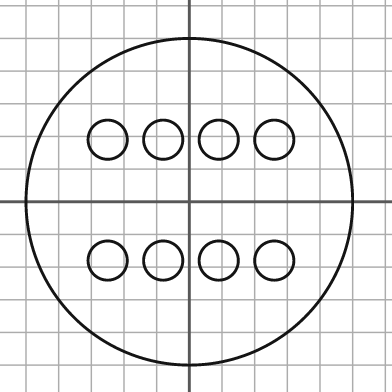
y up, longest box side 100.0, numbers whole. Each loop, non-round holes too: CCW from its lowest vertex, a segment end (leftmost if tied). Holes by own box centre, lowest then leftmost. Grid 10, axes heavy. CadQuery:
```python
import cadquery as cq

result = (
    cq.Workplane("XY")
    .moveTo(0.0, 0.0)
    .circle(50.0)
    .moveTo(-25.0, -18.0)
    .circle(6.0)
    .moveTo(-8.0, -18.0)
    .circle(6.0)
    .moveTo(9.0, -18.0)
    .circle(6.0)
    .moveTo(26.0, -18.0)
    .circle(6.0)
    .moveTo(-25.0, 19.0)
    .circle(6.0)
    .moveTo(-8.0, 19.0)
    .circle(6.0)
    .moveTo(9.0, 19.0)
    .circle(6.0)
    .moveTo(26.0, 19.0)
    .circle(6.0)
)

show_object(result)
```